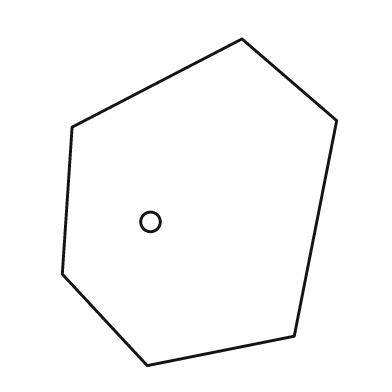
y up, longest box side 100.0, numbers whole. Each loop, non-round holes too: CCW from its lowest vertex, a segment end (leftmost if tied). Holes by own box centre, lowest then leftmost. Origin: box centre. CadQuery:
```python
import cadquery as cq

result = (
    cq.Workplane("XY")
    .moveTo(-16.0, -50.0)
    .lineTo(29.0, -41.0)
    .lineTo(42.0, 25.0)
    .lineTo(13.0, 50.0)
    .lineTo(-39.0, 23.0)
    .lineTo(-42.0, -22.0)
    .close()
    .moveTo(-15.0, -6.0)
    .circle(3.0)
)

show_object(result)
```